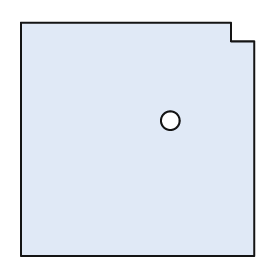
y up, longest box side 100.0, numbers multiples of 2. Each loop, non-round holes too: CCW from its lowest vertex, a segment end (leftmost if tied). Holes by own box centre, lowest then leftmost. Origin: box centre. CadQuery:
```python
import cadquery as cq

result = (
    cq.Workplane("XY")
    .moveTo(-50.0, -50.0)
    .lineTo(50.0, -50.0)
    .lineTo(50.0, 42.0)
    .lineTo(40.0, 42.0)
    .lineTo(40.0, 50.0)
    .lineTo(-50.0, 50.0)
    .close()
    .moveTo(14.0, 8.0)
    .circle(4.0)
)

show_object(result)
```